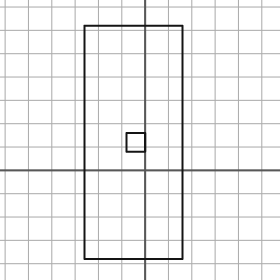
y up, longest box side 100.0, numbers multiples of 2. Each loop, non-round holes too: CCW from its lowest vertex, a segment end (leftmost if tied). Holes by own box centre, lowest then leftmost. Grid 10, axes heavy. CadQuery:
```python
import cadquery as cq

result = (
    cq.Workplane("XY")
    .moveTo(-26.0, -38.0)
    .lineTo(16.0, -38.0)
    .lineTo(16.0, 62.0)
    .lineTo(-26.0, 62.0)
    .close()
    .moveTo(-8.0, 8.0)
    .lineTo(0.0, 8.0)
    .lineTo(0.0, 16.0)
    .lineTo(-8.0, 16.0)
    .close()
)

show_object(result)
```